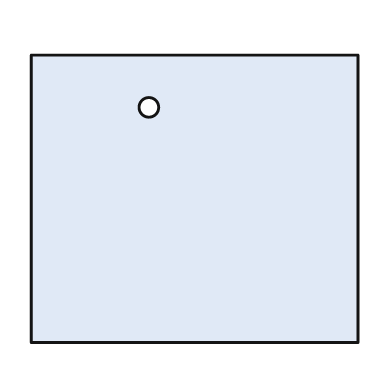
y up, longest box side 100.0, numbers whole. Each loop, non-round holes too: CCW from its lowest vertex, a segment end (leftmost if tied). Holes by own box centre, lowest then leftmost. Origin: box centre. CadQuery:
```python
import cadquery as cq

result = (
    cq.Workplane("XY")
    .moveTo(-50.0, -44.0)
    .lineTo(50.0, -44.0)
    .lineTo(50.0, 44.0)
    .lineTo(-50.0, 44.0)
    .close()
    .moveTo(-14.0, 28.0)
    .circle(3.0)
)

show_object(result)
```